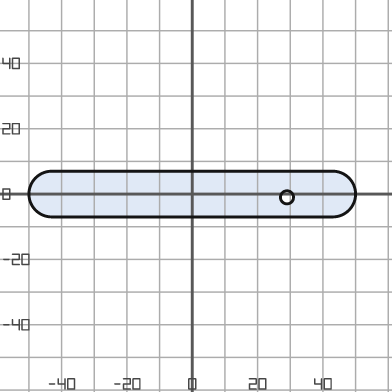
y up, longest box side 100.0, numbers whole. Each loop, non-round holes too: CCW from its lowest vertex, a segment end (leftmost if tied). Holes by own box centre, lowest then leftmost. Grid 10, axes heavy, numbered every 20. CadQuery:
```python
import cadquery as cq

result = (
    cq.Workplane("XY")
    .moveTo(-43.0, -7.0)
    .lineTo(43.0, -7.0)
    .threePointArc((50.0, 0.0), (43.0, 7.0))
    .lineTo(-43.0, 7.0)
    .threePointArc((-50.0, 0.0), (-43.0, -7.0))
    .close()
    .moveTo(29.0, -1.0)
    .circle(2.0)
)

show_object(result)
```